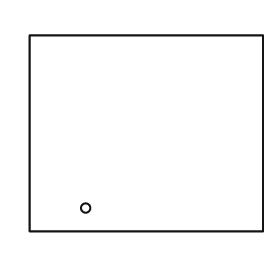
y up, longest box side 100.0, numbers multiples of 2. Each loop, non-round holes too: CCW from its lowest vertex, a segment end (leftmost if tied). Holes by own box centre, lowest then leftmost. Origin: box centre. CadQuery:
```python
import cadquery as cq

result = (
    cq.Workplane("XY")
    .moveTo(-50.0, -42.0)
    .lineTo(50.0, -42.0)
    .lineTo(50.0, 42.0)
    .lineTo(-50.0, 42.0)
    .close()
    .moveTo(-26.0, -32.0)
    .circle(2.0)
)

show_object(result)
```